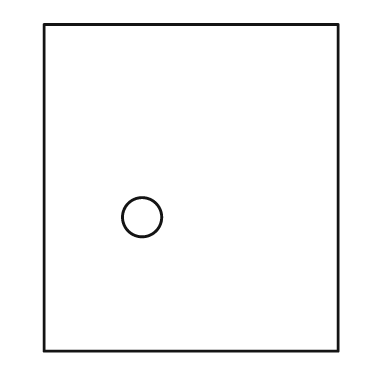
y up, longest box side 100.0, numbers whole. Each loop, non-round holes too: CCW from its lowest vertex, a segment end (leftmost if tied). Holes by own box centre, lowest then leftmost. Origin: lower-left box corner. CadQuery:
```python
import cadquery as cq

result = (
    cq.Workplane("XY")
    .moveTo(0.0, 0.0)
    .lineTo(90.0, 0.0)
    .lineTo(90.0, 100.0)
    .lineTo(0.0, 100.0)
    .close()
    .moveTo(30.0, 41.0)
    .circle(6.0)
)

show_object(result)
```